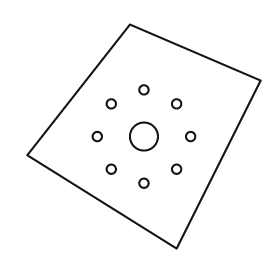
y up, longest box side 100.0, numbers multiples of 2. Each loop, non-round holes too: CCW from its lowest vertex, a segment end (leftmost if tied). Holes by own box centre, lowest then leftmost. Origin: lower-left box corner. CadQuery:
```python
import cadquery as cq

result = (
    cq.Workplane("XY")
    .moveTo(64.0, 0.0)
    .lineTo(100.0, 72.0)
    .lineTo(44.0, 96.0)
    .lineTo(0.0, 40.0)
    .close()
    .moveTo(50.0, 28.0)
    .circle(2.0)
    .moveTo(36.0, 34.0)
    .circle(2.0)
    .moveTo(64.0, 34.0)
    .circle(2.0)
    .moveTo(30.0, 48.0)
    .circle(2.0)
    .moveTo(50.0, 48.0)
    .circle(6.0)
    .moveTo(70.0, 48.0)
    .circle(2.0)
    .moveTo(36.0, 62.0)
    .circle(2.0)
    .moveTo(64.0, 62.0)
    .circle(2.0)
    .moveTo(50.0, 68.0)
    .circle(2.0)
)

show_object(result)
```